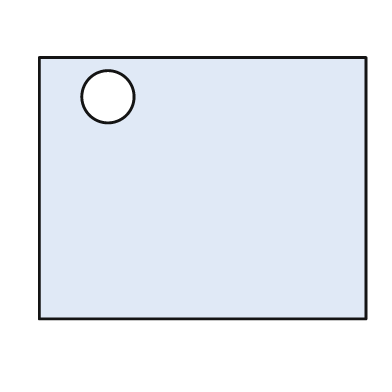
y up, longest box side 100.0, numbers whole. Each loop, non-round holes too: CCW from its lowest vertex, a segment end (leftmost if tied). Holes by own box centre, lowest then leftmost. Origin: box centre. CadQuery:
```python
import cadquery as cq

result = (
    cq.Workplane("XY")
    .moveTo(-50.0, -40.0)
    .lineTo(50.0, -40.0)
    .lineTo(50.0, 40.0)
    .lineTo(-50.0, 40.0)
    .close()
    .moveTo(-29.0, 28.0)
    .circle(8.0)
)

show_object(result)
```